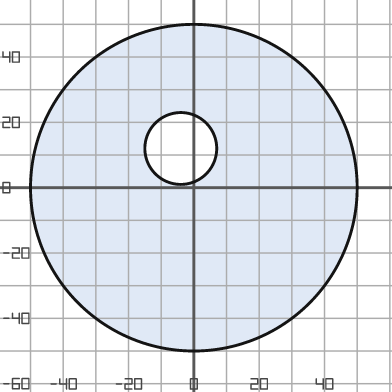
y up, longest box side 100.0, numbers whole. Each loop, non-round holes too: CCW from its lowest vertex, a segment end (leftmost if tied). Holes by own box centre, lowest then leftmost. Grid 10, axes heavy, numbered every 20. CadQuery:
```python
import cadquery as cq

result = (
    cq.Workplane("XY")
    .moveTo(0.0, 0.0)
    .circle(50.0)
    .moveTo(-4.0, 12.0)
    .circle(11.0)
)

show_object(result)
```